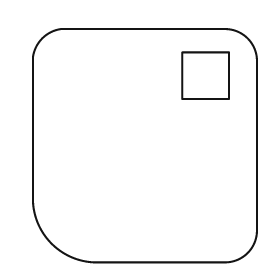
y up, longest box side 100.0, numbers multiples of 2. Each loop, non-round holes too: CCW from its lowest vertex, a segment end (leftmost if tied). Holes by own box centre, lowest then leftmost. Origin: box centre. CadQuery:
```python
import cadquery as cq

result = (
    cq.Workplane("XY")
    .moveTo(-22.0, -50.0)
    .lineTo(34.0, -50.0)
    .threePointArc((44.0, -46.0), (48.0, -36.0))
    .lineTo(48.0, 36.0)
    .threePointArc((44.0, 46.0), (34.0, 50.0))
    .lineTo(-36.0, 50.0)
    .threePointArc((-44.0, 46.0), (-48.0, 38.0))
    .lineTo(-48.0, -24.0)
    .threePointArc((-40.0, -42.0), (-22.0, -50.0))
    .close()
    .moveTo(16.0, 20.0)
    .lineTo(36.0, 20.0)
    .lineTo(36.0, 40.0)
    .lineTo(16.0, 40.0)
    .close()
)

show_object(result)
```